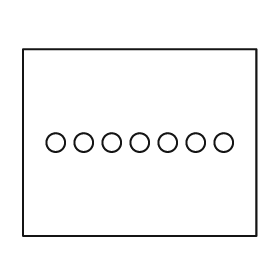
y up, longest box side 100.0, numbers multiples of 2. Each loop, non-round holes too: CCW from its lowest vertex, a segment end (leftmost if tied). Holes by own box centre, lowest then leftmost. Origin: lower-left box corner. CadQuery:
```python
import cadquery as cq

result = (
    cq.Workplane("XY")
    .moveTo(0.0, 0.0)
    .lineTo(100.0, 0.0)
    .lineTo(100.0, 80.0)
    .lineTo(0.0, 80.0)
    .close()
    .moveTo(14.0, 40.0)
    .circle(4.0)
    .moveTo(26.0, 40.0)
    .circle(4.0)
    .moveTo(38.0, 40.0)
    .circle(4.0)
    .moveTo(50.0, 40.0)
    .circle(4.0)
    .moveTo(62.0, 40.0)
    .circle(4.0)
    .moveTo(74.0, 40.0)
    .circle(4.0)
    .moveTo(86.0, 40.0)
    .circle(4.0)
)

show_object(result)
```